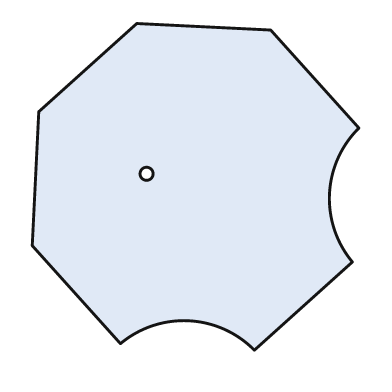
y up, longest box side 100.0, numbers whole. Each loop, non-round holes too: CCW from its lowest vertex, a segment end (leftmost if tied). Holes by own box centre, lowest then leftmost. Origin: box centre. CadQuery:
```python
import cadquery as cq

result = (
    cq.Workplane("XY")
    .moveTo(18.0, -50.0)
    .lineTo(48.0, -23.0)
    .threePointArc((41.0, -2.0), (50.0, 18.0))
    .lineTo(23.0, 48.0)
    .lineTo(-18.0, 50.0)
    .lineTo(-48.0, 23.0)
    .lineTo(-50.0, -18.0)
    .lineTo(-23.0, -48.0)
    .threePointArc((-2.0, -41.0), (18.0, -50.0))
    .close()
    .moveTo(-15.0, 4.0)
    .circle(2.0)
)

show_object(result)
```